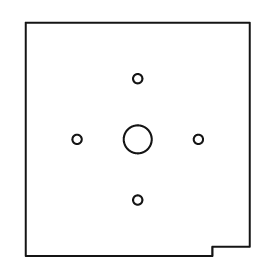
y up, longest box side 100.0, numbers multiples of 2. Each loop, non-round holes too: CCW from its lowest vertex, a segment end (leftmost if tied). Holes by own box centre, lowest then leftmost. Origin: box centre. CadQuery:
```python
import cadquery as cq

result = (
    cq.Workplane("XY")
    .moveTo(-48.0, -50.0)
    .lineTo(32.0, -50.0)
    .lineTo(32.0, -46.0)
    .lineTo(48.0, -46.0)
    .lineTo(48.0, 50.0)
    .lineTo(-48.0, 50.0)
    .close()
    .moveTo(0.0, -26.0)
    .circle(2.0)
    .moveTo(-26.0, 0.0)
    .circle(2.0)
    .moveTo(0.0, 0.0)
    .circle(6.0)
    .moveTo(26.0, 0.0)
    .circle(2.0)
    .moveTo(0.0, 26.0)
    .circle(2.0)
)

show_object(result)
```